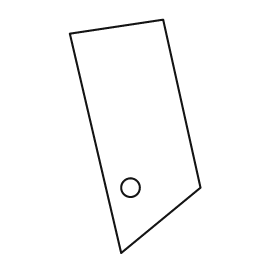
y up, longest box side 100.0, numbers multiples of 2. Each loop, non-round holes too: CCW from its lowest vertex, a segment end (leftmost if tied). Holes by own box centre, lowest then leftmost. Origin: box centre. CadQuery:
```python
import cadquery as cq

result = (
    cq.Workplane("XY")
    .moveTo(-6.0, -50.0)
    .lineTo(28.0, -22.0)
    .lineTo(12.0, 50.0)
    .lineTo(-28.0, 44.0)
    .close()
    .moveTo(-2.0, -22.0)
    .circle(4.0)
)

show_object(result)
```